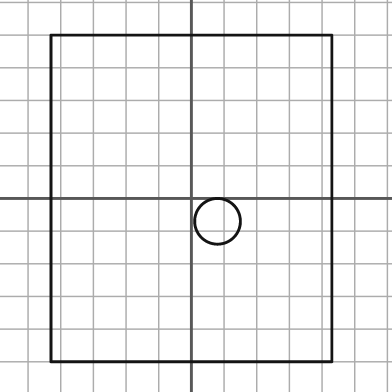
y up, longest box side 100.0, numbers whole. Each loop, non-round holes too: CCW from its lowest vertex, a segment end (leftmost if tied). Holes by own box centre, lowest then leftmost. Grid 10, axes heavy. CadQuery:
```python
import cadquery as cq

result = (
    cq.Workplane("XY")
    .moveTo(-43.0, -50.0)
    .lineTo(43.0, -50.0)
    .lineTo(43.0, 50.0)
    .lineTo(-43.0, 50.0)
    .close()
    .moveTo(8.0, -7.0)
    .circle(7.0)
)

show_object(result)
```